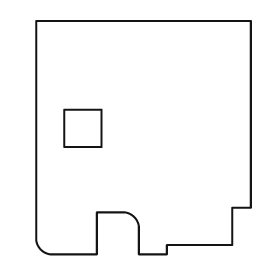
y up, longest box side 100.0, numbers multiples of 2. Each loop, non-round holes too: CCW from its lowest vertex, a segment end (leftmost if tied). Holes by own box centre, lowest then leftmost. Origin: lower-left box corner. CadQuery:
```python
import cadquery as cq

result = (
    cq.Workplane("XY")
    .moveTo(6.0, 0.0)
    .lineTo(26.0, 0.0)
    .lineTo(26.0, 18.0)
    .lineTo(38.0, 18.0)
    .threePointArc((42.0, 16.0), (44.0, 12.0))
    .lineTo(44.0, 0.0)
    .lineTo(56.0, 0.0)
    .lineTo(56.0, 4.0)
    .lineTo(84.0, 4.0)
    .lineTo(84.0, 20.0)
    .lineTo(92.0, 20.0)
    .lineTo(92.0, 100.0)
    .lineTo(0.0, 100.0)
    .lineTo(0.0, 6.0)
    .threePointArc((2.0, 2.0), (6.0, 0.0))
    .close()
    .moveTo(12.0, 46.0)
    .lineTo(28.0, 46.0)
    .lineTo(28.0, 62.0)
    .lineTo(12.0, 62.0)
    .close()
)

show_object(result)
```